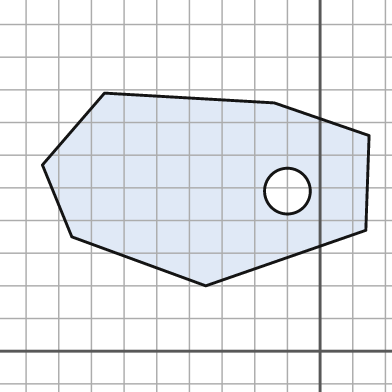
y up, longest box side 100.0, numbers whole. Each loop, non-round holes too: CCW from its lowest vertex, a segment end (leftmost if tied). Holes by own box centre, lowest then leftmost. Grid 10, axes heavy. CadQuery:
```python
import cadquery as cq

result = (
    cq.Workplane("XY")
    .moveTo(-35.0, 20.0)
    .lineTo(14.0, 37.0)
    .lineTo(15.0, 66.0)
    .lineTo(-14.0, 76.0)
    .lineTo(-66.0, 79.0)
    .lineTo(-85.0, 57.0)
    .lineTo(-76.0, 35.0)
    .close()
    .moveTo(-10.0, 49.0)
    .circle(7.0)
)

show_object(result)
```